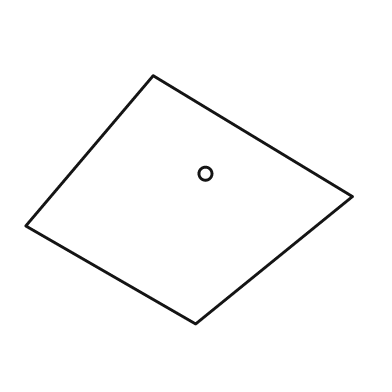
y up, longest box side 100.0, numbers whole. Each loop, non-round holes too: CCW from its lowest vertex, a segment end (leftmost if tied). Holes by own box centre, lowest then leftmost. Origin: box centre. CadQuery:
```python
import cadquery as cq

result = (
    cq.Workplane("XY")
    .moveTo(2.0, -38.0)
    .lineTo(50.0, 1.0)
    .lineTo(-11.0, 38.0)
    .lineTo(-50.0, -8.0)
    .close()
    .moveTo(5.0, 8.0)
    .circle(2.0)
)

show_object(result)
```